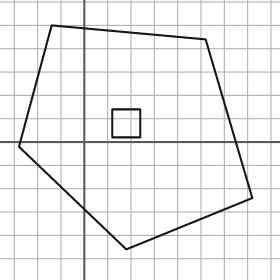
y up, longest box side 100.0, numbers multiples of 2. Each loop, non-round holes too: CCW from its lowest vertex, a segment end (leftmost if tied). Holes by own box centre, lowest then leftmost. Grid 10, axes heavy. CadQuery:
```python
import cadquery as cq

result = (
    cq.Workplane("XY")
    .moveTo(18.0, -46.0)
    .lineTo(72.0, -24.0)
    .lineTo(52.0, 44.0)
    .lineTo(-14.0, 50.0)
    .lineTo(-28.0, -2.0)
    .close()
    .moveTo(12.0, 2.0)
    .lineTo(24.0, 2.0)
    .lineTo(24.0, 14.0)
    .lineTo(12.0, 14.0)
    .close()
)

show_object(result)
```